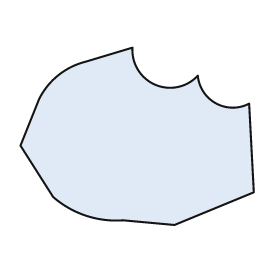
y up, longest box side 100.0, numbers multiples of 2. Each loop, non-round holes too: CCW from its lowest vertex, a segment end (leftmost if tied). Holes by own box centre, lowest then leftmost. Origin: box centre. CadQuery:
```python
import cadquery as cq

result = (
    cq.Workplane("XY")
    .moveTo(16.0, -38.0)
    .lineTo(50.0, -24.0)
    .lineTo(48.0, 14.0)
    .threePointArc((34.0, 14.0), (26.0, 26.0))
    .threePointArc((8.0, 22.0), (-2.0, 38.0))
    .lineTo(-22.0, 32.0)
    .threePointArc((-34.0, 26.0), (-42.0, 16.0))
    .lineTo(-50.0, -4.0)
    .lineTo(-36.0, -26.0)
    .threePointArc((-22.0, -34.0), (-6.0, -36.0))
    .close()
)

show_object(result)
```